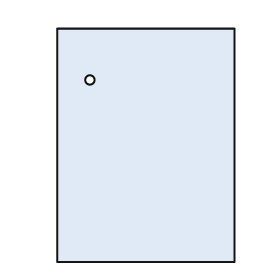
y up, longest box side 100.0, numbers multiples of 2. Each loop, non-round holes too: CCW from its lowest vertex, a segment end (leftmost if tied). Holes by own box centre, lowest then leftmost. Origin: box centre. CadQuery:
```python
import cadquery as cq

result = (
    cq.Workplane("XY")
    .moveTo(-38.0, -50.0)
    .lineTo(38.0, -50.0)
    .lineTo(38.0, 50.0)
    .lineTo(-38.0, 50.0)
    .close()
    .moveTo(-24.0, 28.0)
    .circle(2.0)
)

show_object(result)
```